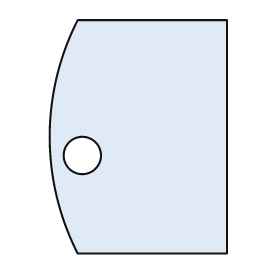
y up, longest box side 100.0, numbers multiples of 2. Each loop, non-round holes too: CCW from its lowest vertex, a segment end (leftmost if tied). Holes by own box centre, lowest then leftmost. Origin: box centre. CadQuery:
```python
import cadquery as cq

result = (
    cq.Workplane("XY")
    .moveTo(-26.0, -50.0)
    .lineTo(38.0, -50.0)
    .lineTo(38.0, 50.0)
    .lineTo(-26.0, 50.0)
    .threePointArc((-38.0, 0.0), (-26.0, -50.0))
    .close()
    .moveTo(-24.0, -8.0)
    .circle(8.0)
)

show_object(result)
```